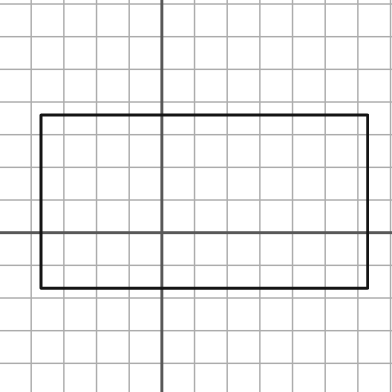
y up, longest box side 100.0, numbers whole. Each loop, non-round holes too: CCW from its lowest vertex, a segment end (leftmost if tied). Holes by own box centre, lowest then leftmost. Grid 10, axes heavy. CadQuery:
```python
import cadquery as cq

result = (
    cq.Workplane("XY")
    .moveTo(-37.0, -17.0)
    .lineTo(63.0, -17.0)
    .lineTo(63.0, 36.0)
    .lineTo(-37.0, 36.0)
    .close()
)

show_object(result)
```